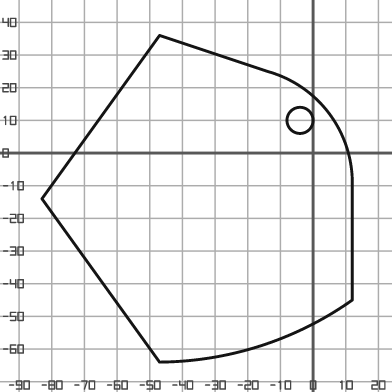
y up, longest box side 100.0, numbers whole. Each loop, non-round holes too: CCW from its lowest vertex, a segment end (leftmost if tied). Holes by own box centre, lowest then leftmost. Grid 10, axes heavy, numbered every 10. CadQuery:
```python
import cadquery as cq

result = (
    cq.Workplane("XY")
    .moveTo(-47.0, -64.0)
    .threePointArc((-16.0, -59.0), (12.0, -45.0))
    .lineTo(12.0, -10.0)
    .threePointArc((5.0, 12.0), (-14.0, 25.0))
    .lineTo(-47.0, 36.0)
    .lineTo(-83.0, -14.0)
    .close()
    .moveTo(-4.0, 10.0)
    .circle(4.0)
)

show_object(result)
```